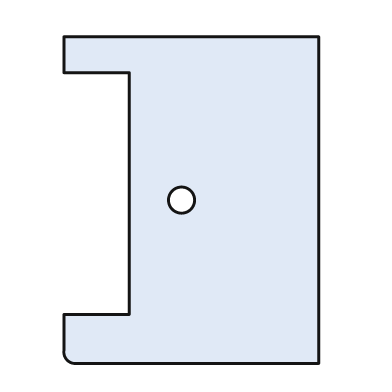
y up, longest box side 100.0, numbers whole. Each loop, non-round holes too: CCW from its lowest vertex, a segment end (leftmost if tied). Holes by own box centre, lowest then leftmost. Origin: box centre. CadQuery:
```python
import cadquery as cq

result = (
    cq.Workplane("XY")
    .moveTo(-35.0, -50.0)
    .lineTo(39.0, -50.0)
    .lineTo(39.0, 50.0)
    .lineTo(-39.0, 50.0)
    .lineTo(-39.0, 39.0)
    .lineTo(-19.0, 39.0)
    .lineTo(-19.0, -35.0)
    .lineTo(-39.0, -35.0)
    .lineTo(-39.0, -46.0)
    .threePointArc((-38.0, -49.0), (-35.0, -50.0))
    .close()
    .moveTo(-3.0, 0.0)
    .circle(4.0)
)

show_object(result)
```